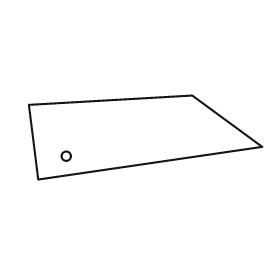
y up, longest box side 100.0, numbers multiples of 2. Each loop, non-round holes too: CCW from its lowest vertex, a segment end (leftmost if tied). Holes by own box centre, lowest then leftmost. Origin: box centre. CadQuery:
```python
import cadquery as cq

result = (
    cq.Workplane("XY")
    .moveTo(-46.0, -18.0)
    .lineTo(50.0, -4.0)
    .lineTo(20.0, 18.0)
    .lineTo(-50.0, 14.0)
    .close()
    .moveTo(-34.0, -8.0)
    .circle(2.0)
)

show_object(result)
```